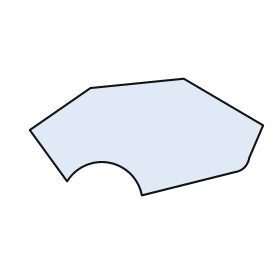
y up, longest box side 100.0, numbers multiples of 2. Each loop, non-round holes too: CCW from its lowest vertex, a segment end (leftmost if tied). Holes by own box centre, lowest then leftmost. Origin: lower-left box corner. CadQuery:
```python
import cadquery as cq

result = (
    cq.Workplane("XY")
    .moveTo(48.0, 0.0)
    .lineTo(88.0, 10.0)
    .threePointArc((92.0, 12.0), (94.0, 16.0))
    .lineTo(100.0, 30.0)
    .lineTo(66.0, 50.0)
    .lineTo(26.0, 46.0)
    .lineTo(0.0, 28.0)
    .lineTo(16.0, 6.0)
    .threePointArc((34.0, 14.0), (48.0, 0.0))
    .close()
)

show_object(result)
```